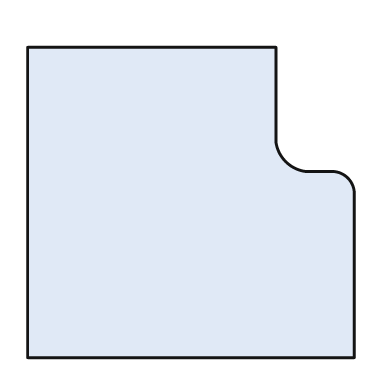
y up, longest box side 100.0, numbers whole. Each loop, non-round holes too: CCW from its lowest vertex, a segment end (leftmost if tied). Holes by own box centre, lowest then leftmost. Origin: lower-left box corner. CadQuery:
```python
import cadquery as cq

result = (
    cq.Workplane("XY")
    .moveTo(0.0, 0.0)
    .lineTo(100.0, 0.0)
    .lineTo(100.0, 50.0)
    .threePointArc((98.0, 55.0), (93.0, 57.0))
    .lineTo(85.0, 57.0)
    .threePointArc((79.0, 60.0), (76.0, 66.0))
    .lineTo(76.0, 95.0)
    .lineTo(0.0, 95.0)
    .close()
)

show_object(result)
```